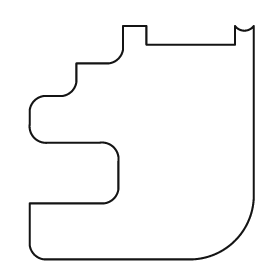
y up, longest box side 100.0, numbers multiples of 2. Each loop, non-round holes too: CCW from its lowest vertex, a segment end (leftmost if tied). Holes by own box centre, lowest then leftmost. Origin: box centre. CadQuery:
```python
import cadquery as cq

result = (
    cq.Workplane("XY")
    .moveTo(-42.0, -50.0)
    .lineTo(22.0, -50.0)
    .threePointArc((40.0, -42.0), (48.0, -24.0))
    .lineTo(48.0, 50.0)
    .threePointArc((44.0, 48.0), (40.0, 50.0))
    .lineTo(40.0, 42.0)
    .lineTo(2.0, 42.0)
    .lineTo(2.0, 50.0)
    .lineTo(-8.0, 50.0)
    .lineTo(-8.0, 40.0)
    .threePointArc((-10.0, 36.0), (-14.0, 34.0))
    .lineTo(-28.0, 34.0)
    .lineTo(-28.0, 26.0)
    .threePointArc((-30.0, 22.0), (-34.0, 20.0))
    .lineTo(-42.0, 20.0)
    .threePointArc((-46.0, 18.0), (-48.0, 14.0))
    .lineTo(-48.0, 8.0)
    .threePointArc((-46.0, 2.0), (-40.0, 0.0))
    .lineTo(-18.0, 0.0)
    .threePointArc((-12.0, -2.0), (-10.0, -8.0))
    .lineTo(-10.0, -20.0)
    .threePointArc((-12.0, -24.0), (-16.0, -26.0))
    .lineTo(-48.0, -26.0)
    .lineTo(-48.0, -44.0)
    .threePointArc((-46.0, -48.0), (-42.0, -50.0))
    .close()
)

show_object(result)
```